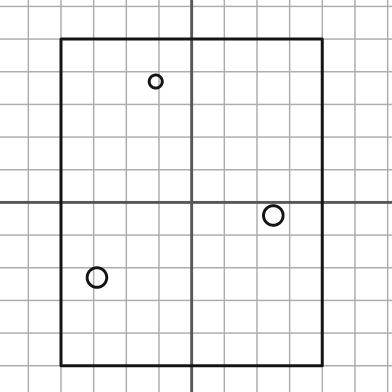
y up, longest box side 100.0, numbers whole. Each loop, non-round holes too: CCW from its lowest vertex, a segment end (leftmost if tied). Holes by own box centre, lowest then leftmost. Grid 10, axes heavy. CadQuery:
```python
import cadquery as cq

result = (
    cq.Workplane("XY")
    .moveTo(-40.0, -50.0)
    .lineTo(40.0, -50.0)
    .lineTo(40.0, 50.0)
    .lineTo(-40.0, 50.0)
    .close()
    .moveTo(-29.0, -23.0)
    .circle(3.0)
    .moveTo(25.0, -4.0)
    .circle(3.0)
    .moveTo(-11.0, 37.0)
    .circle(2.0)
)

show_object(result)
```